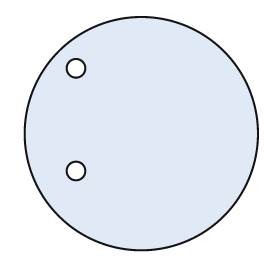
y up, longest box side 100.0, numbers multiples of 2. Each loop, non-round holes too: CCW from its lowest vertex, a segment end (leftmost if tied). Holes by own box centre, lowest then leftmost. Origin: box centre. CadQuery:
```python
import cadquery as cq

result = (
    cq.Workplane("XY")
    .moveTo(0.0, 0.0)
    .circle(50.0)
    .moveTo(-28.0, -16.0)
    .circle(4.0)
    .moveTo(-28.0, 28.0)
    .circle(4.0)
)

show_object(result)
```